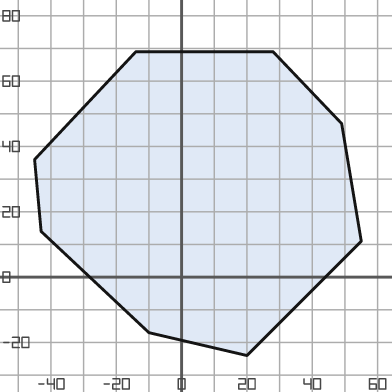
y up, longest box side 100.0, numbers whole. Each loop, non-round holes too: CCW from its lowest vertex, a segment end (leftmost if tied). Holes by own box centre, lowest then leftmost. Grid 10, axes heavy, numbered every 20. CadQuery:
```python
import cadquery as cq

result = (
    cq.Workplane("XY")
    .moveTo(20.0, -24.0)
    .lineTo(55.0, 11.0)
    .lineTo(49.0, 47.0)
    .lineTo(28.0, 69.0)
    .lineTo(-14.0, 69.0)
    .lineTo(-45.0, 36.0)
    .lineTo(-43.0, 14.0)
    .lineTo(-10.0, -17.0)
    .close()
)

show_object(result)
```